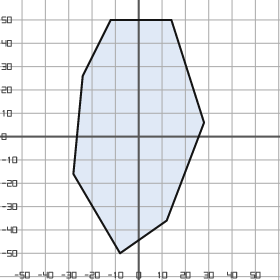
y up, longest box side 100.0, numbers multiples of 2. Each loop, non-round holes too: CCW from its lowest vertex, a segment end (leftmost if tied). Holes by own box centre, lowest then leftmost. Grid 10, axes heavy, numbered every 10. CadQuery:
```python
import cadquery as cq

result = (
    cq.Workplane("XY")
    .moveTo(-8.0, -50.0)
    .lineTo(12.0, -36.0)
    .lineTo(28.0, 6.0)
    .lineTo(14.0, 50.0)
    .lineTo(-12.0, 50.0)
    .lineTo(-24.0, 26.0)
    .lineTo(-28.0, -16.0)
    .close()
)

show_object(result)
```